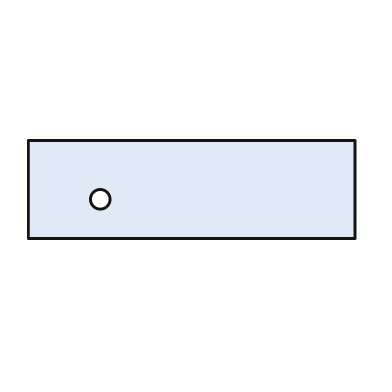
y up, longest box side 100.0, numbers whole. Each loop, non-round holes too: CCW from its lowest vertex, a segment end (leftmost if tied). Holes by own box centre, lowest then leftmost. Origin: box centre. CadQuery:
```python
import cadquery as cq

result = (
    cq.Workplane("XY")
    .moveTo(-50.0, -15.0)
    .lineTo(50.0, -15.0)
    .lineTo(50.0, 15.0)
    .lineTo(-50.0, 15.0)
    .close()
    .moveTo(-28.0, -3.0)
    .circle(3.0)
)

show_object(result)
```